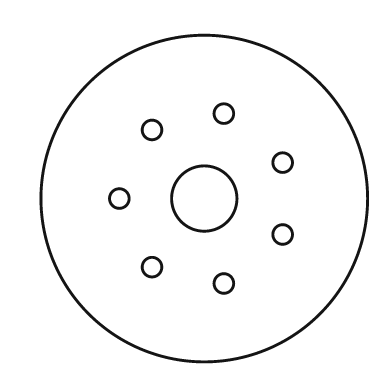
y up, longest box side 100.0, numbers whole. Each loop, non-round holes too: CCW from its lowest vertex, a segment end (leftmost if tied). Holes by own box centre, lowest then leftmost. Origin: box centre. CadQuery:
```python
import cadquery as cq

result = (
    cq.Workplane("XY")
    .moveTo(0.0, 0.0)
    .circle(50.0)
    .moveTo(6.0, -26.0)
    .circle(3.0)
    .moveTo(-16.0, -21.0)
    .circle(3.0)
    .moveTo(24.0, -11.0)
    .circle(3.0)
    .moveTo(-26.0, 0.0)
    .circle(3.0)
    .moveTo(0.0, 0.0)
    .circle(10.0)
    .moveTo(24.0, 11.0)
    .circle(3.0)
    .moveTo(-16.0, 21.0)
    .circle(3.0)
    .moveTo(6.0, 26.0)
    .circle(3.0)
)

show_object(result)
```